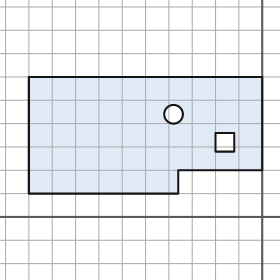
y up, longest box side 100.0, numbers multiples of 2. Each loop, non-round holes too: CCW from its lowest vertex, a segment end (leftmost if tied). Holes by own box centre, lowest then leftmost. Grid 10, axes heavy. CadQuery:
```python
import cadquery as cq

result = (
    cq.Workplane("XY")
    .moveTo(-100.0, 10.0)
    .lineTo(-36.0, 10.0)
    .lineTo(-36.0, 20.0)
    .lineTo(0.0, 20.0)
    .lineTo(0.0, 60.0)
    .lineTo(-100.0, 60.0)
    .close()
    .moveTo(-20.0, 28.0)
    .lineTo(-12.0, 28.0)
    .lineTo(-12.0, 36.0)
    .lineTo(-20.0, 36.0)
    .close()
    .moveTo(-38.0, 44.0)
    .circle(4.0)
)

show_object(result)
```